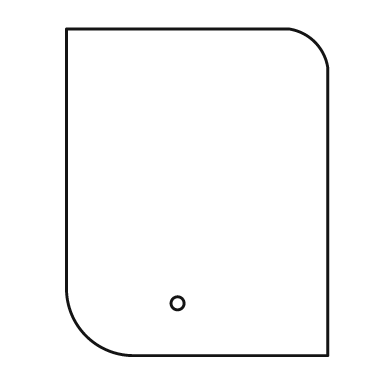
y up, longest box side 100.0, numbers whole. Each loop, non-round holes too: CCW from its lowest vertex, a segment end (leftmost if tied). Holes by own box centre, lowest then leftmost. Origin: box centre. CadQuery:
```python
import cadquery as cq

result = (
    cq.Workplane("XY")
    .moveTo(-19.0, -50.0)
    .lineTo(40.0, -50.0)
    .lineTo(40.0, 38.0)
    .threePointArc((36.0, 46.0), (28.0, 50.0))
    .lineTo(-40.0, 50.0)
    .lineTo(-40.0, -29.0)
    .threePointArc((-34.0, -44.0), (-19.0, -50.0))
    .close()
    .moveTo(-6.0, -34.0)
    .circle(2.0)
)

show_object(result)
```